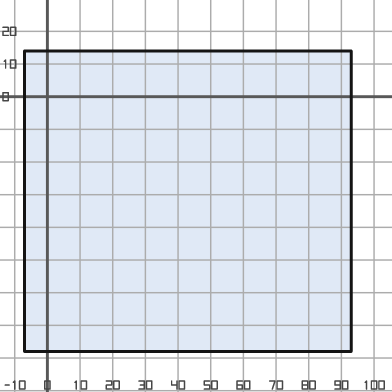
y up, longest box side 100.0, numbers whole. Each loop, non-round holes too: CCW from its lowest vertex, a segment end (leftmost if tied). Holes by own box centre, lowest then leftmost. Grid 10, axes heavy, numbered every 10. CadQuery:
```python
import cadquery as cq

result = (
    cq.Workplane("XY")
    .moveTo(-7.0, -78.0)
    .lineTo(93.0, -78.0)
    .lineTo(93.0, 14.0)
    .lineTo(-7.0, 14.0)
    .close()
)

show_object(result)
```